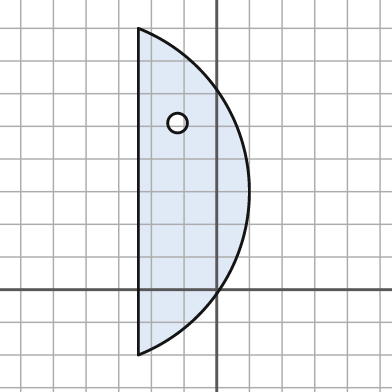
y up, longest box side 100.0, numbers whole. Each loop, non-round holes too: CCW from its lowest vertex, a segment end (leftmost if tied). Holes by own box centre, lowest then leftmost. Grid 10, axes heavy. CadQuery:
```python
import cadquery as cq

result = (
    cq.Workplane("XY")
    .moveTo(-24.0, -20.0)
    .threePointArc((10.0, 30.0), (-24.0, 80.0))
    .close()
    .moveTo(-12.0, 51.0)
    .circle(3.0)
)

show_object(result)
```